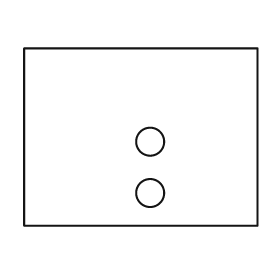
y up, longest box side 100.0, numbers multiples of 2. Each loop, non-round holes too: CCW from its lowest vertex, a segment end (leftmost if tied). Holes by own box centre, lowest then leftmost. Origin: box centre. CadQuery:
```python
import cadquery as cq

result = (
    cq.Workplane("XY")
    .moveTo(-50.0, -38.0)
    .lineTo(50.0, -38.0)
    .lineTo(50.0, 38.0)
    .lineTo(-50.0, 38.0)
    .close()
    .moveTo(4.0, -24.0)
    .circle(6.0)
    .moveTo(4.0, -2.0)
    .circle(6.0)
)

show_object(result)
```